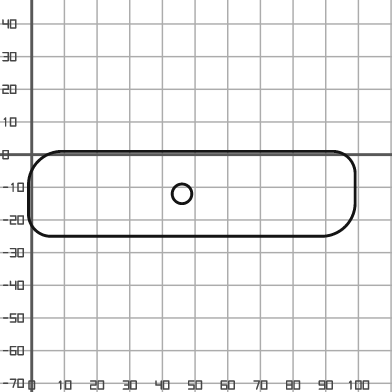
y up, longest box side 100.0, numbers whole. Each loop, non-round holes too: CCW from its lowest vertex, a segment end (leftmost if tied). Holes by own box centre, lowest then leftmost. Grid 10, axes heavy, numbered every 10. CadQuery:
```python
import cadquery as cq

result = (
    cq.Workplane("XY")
    .moveTo(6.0, -25.0)
    .lineTo(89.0, -25.0)
    .threePointArc((96.0, -22.0), (99.0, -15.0))
    .lineTo(99.0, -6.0)
    .threePointArc((97.0, -1.0), (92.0, 1.0))
    .lineTo(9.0, 1.0)
    .threePointArc((2.0, -2.0), (-1.0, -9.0))
    .lineTo(-1.0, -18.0)
    .threePointArc((1.0, -23.0), (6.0, -25.0))
    .close()
    .moveTo(46.0, -12.0)
    .circle(3.0)
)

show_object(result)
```